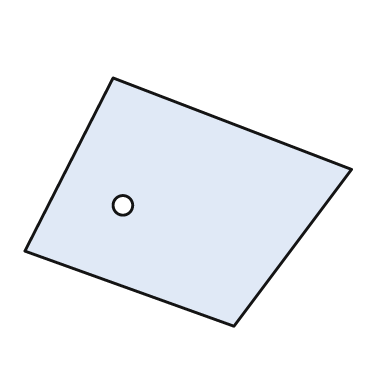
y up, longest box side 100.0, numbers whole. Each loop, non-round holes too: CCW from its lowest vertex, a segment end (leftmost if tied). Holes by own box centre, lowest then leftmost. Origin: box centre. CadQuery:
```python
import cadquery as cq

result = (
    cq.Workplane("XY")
    .moveTo(14.0, -38.0)
    .lineTo(50.0, 10.0)
    .lineTo(-23.0, 38.0)
    .lineTo(-50.0, -15.0)
    .close()
    .moveTo(-20.0, -1.0)
    .circle(3.0)
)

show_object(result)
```